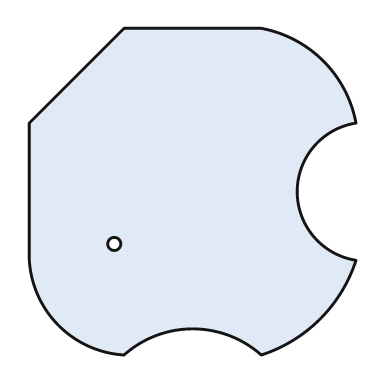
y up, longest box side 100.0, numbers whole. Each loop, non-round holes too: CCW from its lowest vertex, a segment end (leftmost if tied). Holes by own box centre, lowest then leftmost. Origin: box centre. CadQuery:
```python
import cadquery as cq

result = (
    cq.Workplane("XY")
    .moveTo(-21.0, -50.0)
    .threePointArc((0.0, -42.0), (21.0, -50.0))
    .threePointArc((39.0, -39.0), (50.0, -21.0))
    .threePointArc((32.0, 0.0), (50.0, 21.0))
    .threePointArc((40.0, 40.0), (21.0, 50.0))
    .lineTo(-21.0, 50.0)
    .lineTo(-50.0, 21.0)
    .lineTo(-50.0, -21.0)
    .threePointArc((-41.0, -41.0), (-21.0, -50.0))
    .close()
    .moveTo(-24.0, -16.0)
    .circle(2.0)
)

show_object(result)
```